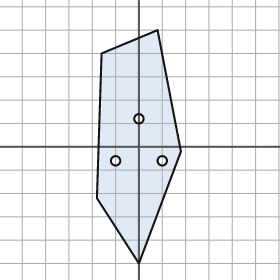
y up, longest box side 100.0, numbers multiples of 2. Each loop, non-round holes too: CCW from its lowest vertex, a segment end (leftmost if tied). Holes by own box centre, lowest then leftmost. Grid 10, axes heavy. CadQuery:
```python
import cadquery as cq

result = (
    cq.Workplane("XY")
    .moveTo(0.0, -50.0)
    .lineTo(18.0, -2.0)
    .lineTo(8.0, 50.0)
    .lineTo(-16.0, 40.0)
    .lineTo(-18.0, -22.0)
    .close()
    .moveTo(-10.0, -6.0)
    .circle(2.0)
    .moveTo(10.0, -6.0)
    .circle(2.0)
    .moveTo(0.0, 12.0)
    .circle(2.0)
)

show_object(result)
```